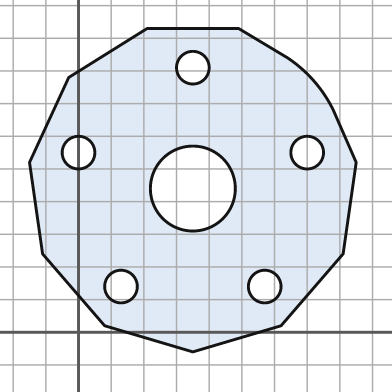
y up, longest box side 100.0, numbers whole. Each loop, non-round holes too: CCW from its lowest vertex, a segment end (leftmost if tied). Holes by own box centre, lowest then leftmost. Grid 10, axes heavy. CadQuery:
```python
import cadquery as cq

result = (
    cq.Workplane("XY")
    .moveTo(35.0, -6.0)
    .lineTo(62.0, 2.0)
    .lineTo(81.0, 24.0)
    .lineTo(85.0, 52.0)
    .lineTo(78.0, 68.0)
    .threePointArc((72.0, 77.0), (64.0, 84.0))
    .lineTo(49.0, 93.0)
    .lineTo(21.0, 93.0)
    .lineTo(-3.0, 78.0)
    .lineTo(-15.0, 52.0)
    .lineTo(-11.0, 24.0)
    .lineTo(8.0, 2.0)
    .close()
    .moveTo(13.0, 14.0)
    .circle(5.0)
    .moveTo(57.0, 14.0)
    .circle(5.0)
    .moveTo(35.0, 44.0)
    .circle(13.0)
    .moveTo(0.0, 55.0)
    .circle(5.0)
    .moveTo(70.0, 55.0)
    .circle(5.0)
    .moveTo(35.0, 81.0)
    .circle(5.0)
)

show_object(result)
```